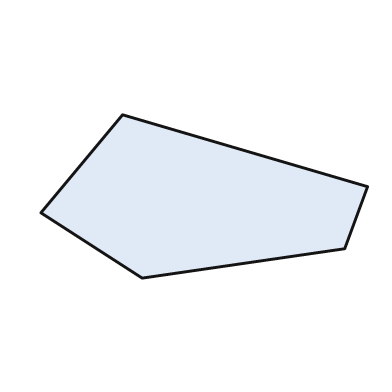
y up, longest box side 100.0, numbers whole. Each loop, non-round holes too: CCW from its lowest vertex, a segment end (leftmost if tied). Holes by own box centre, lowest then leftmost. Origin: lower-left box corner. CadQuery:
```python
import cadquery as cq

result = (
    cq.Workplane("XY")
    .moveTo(31.0, 0.0)
    .lineTo(93.0, 9.0)
    .lineTo(100.0, 28.0)
    .lineTo(25.0, 50.0)
    .lineTo(0.0, 20.0)
    .close()
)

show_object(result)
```